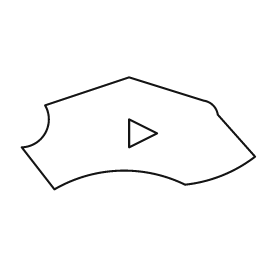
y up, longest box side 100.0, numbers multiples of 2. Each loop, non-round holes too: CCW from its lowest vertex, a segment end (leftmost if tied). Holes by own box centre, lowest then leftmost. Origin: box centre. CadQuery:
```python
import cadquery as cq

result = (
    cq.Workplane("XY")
    .moveTo(-36.0, -24.0)
    .threePointArc((-8.0, -16.0), (20.0, -22.0))
    .threePointArc((36.0, -18.0), (50.0, -10.0))
    .lineTo(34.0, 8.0)
    .threePointArc((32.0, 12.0), (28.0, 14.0))
    .lineTo(-4.0, 24.0)
    .lineTo(-40.0, 12.0)
    .threePointArc((-40.0, 0.0), (-50.0, -6.0))
    .close()
    .moveTo(-4.0, -6.0)
    .lineTo(8.0, 0.0)
    .lineTo(-4.0, 6.0)
    .close()
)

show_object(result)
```